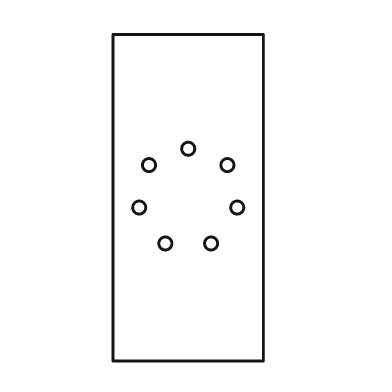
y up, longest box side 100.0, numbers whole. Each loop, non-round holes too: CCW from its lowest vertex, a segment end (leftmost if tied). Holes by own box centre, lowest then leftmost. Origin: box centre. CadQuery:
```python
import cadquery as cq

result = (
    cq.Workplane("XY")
    .moveTo(-23.0, -50.0)
    .lineTo(23.0, -50.0)
    .lineTo(23.0, 50.0)
    .lineTo(-23.0, 50.0)
    .close()
    .moveTo(-7.0, -14.0)
    .circle(2.0)
    .moveTo(7.0, -14.0)
    .circle(2.0)
    .moveTo(-15.0, -3.0)
    .circle(2.0)
    .moveTo(15.0, -3.0)
    .circle(2.0)
    .moveTo(-12.0, 10.0)
    .circle(2.0)
    .moveTo(12.0, 10.0)
    .circle(2.0)
    .moveTo(0.0, 15.0)
    .circle(2.0)
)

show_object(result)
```